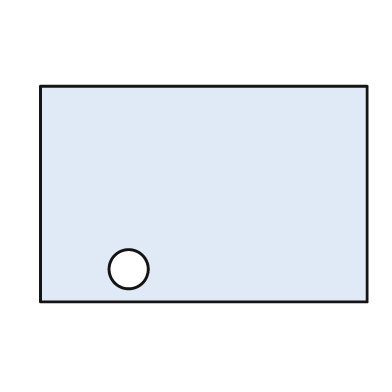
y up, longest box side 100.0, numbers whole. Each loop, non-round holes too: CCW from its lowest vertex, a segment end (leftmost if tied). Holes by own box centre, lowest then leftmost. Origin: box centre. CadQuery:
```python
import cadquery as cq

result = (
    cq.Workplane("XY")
    .moveTo(-50.0, -33.0)
    .lineTo(50.0, -33.0)
    .lineTo(50.0, 33.0)
    .lineTo(-50.0, 33.0)
    .close()
    .moveTo(-23.0, -23.0)
    .circle(6.0)
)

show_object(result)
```